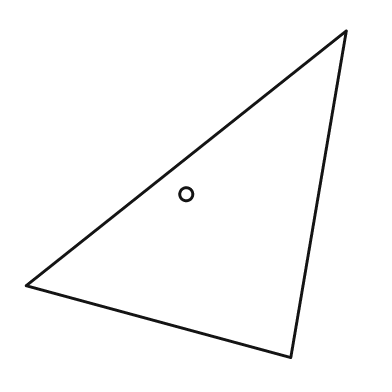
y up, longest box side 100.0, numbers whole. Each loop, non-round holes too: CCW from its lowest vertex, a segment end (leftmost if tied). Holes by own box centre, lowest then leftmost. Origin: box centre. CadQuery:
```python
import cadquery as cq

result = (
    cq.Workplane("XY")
    .moveTo(32.0, -50.0)
    .lineTo(49.0, 50.0)
    .lineTo(-49.0, -28.0)
    .close()
    .moveTo(0.0, 0.0)
    .circle(2.0)
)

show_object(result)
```